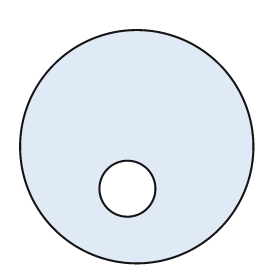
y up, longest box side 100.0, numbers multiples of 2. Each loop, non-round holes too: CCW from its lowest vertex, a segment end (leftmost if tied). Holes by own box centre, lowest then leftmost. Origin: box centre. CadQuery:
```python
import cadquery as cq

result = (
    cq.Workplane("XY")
    .moveTo(0.0, 0.0)
    .circle(50.0)
    .moveTo(-4.0, -18.0)
    .circle(12.0)
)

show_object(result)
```